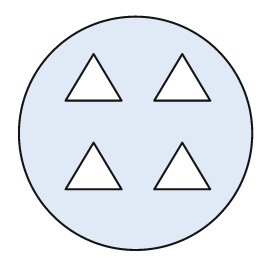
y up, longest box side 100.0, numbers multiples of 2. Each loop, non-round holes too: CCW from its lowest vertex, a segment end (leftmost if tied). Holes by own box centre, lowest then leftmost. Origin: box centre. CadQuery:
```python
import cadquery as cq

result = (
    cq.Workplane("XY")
    .moveTo(0.0, 0.0)
    .circle(50.0)
    .moveTo(-30.0, -24.0)
    .lineTo(-6.0, -24.0)
    .lineTo(-18.0, -4.0)
    .close()
    .moveTo(8.0, -24.0)
    .lineTo(32.0, -24.0)
    .lineTo(20.0, -4.0)
    .close()
    .moveTo(-30.0, 14.0)
    .lineTo(-6.0, 14.0)
    .lineTo(-18.0, 34.0)
    .close()
    .moveTo(8.0, 14.0)
    .lineTo(32.0, 14.0)
    .lineTo(20.0, 34.0)
    .close()
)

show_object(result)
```